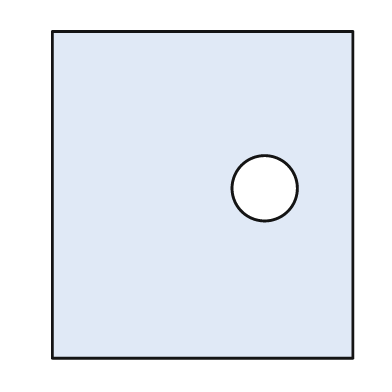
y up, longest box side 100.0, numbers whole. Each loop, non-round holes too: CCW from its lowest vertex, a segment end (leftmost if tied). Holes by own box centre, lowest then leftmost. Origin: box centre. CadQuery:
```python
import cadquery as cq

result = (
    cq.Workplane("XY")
    .moveTo(-46.0, -50.0)
    .lineTo(46.0, -50.0)
    .lineTo(46.0, 50.0)
    .lineTo(-46.0, 50.0)
    .close()
    .moveTo(19.0, 2.0)
    .circle(10.0)
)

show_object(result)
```